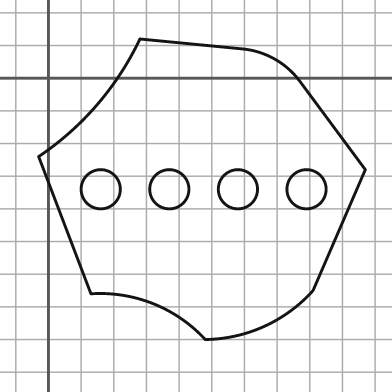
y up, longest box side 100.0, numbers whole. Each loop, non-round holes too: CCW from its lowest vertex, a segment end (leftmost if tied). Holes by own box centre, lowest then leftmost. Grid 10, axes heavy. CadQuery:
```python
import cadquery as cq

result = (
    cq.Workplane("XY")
    .moveTo(48.0, -80.0)
    .threePointArc((66.0, -76.0), (81.0, -65.0))
    .lineTo(97.0, -28.0)
    .lineTo(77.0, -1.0)
    .threePointArc((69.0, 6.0), (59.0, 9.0))
    .lineTo(28.0, 12.0)
    .threePointArc((15.0, -8.0), (-3.0, -24.0))
    .lineTo(13.0, -66.0)
    .threePointArc((32.0, -69.0), (48.0, -80.0))
    .close()
    .moveTo(16.0, -34.0)
    .circle(6.0)
    .moveTo(37.0, -34.0)
    .circle(6.0)
    .moveTo(58.0, -34.0)
    .circle(6.0)
    .moveTo(79.0, -34.0)
    .circle(6.0)
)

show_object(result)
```